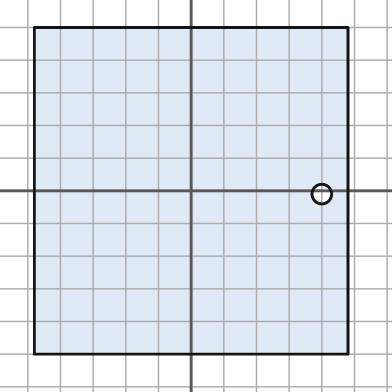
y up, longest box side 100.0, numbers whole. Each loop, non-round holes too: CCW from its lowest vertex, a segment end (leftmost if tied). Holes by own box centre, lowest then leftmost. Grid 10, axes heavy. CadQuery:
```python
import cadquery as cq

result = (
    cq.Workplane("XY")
    .moveTo(-48.0, -50.0)
    .lineTo(48.0, -50.0)
    .lineTo(48.0, 50.0)
    .lineTo(-48.0, 50.0)
    .close()
    .moveTo(40.0, -1.0)
    .circle(3.0)
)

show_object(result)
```